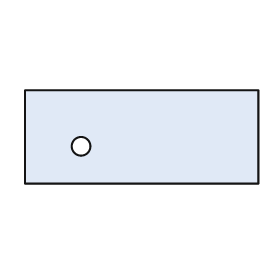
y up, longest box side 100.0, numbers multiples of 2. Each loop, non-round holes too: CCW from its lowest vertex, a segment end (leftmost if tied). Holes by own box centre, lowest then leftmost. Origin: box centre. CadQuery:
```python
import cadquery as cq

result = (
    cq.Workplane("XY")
    .moveTo(-50.0, -20.0)
    .lineTo(50.0, -20.0)
    .lineTo(50.0, 20.0)
    .lineTo(-50.0, 20.0)
    .close()
    .moveTo(-26.0, -4.0)
    .circle(4.0)
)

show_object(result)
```